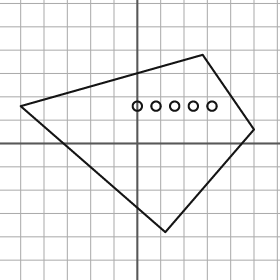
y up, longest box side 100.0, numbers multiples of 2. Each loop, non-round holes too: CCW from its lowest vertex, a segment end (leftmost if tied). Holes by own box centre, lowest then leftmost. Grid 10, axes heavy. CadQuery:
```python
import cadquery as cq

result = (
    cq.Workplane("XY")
    .moveTo(12.0, -38.0)
    .lineTo(50.0, 6.0)
    .lineTo(28.0, 38.0)
    .lineTo(-50.0, 16.0)
    .close()
    .moveTo(0.0, 16.0)
    .circle(2.0)
    .moveTo(8.0, 16.0)
    .circle(2.0)
    .moveTo(16.0, 16.0)
    .circle(2.0)
    .moveTo(24.0, 16.0)
    .circle(2.0)
    .moveTo(32.0, 16.0)
    .circle(2.0)
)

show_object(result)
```